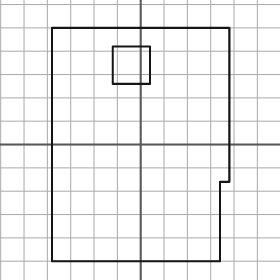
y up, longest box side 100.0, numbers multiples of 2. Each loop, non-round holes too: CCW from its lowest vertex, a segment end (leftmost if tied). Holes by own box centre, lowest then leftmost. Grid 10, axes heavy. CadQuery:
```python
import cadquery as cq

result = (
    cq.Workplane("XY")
    .moveTo(-38.0, -50.0)
    .lineTo(34.0, -50.0)
    .lineTo(34.0, -16.0)
    .lineTo(38.0, -16.0)
    .lineTo(38.0, 50.0)
    .lineTo(-38.0, 50.0)
    .close()
    .moveTo(-12.0, 26.0)
    .lineTo(4.0, 26.0)
    .lineTo(4.0, 42.0)
    .lineTo(-12.0, 42.0)
    .close()
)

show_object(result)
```